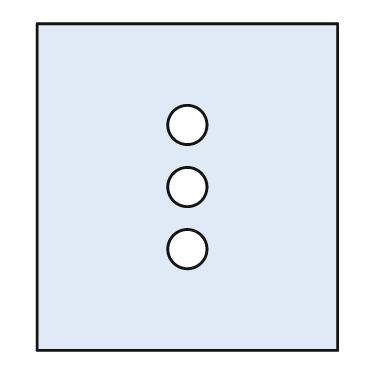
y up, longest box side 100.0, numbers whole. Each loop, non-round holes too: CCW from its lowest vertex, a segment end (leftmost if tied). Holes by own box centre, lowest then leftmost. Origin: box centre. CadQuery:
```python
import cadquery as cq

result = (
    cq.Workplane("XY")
    .moveTo(-46.0, -50.0)
    .lineTo(46.0, -50.0)
    .lineTo(46.0, 50.0)
    .lineTo(-46.0, 50.0)
    .close()
    .moveTo(0.0, -19.0)
    .circle(6.0)
    .moveTo(0.0, 0.0)
    .circle(6.0)
    .moveTo(0.0, 19.0)
    .circle(6.0)
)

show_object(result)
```